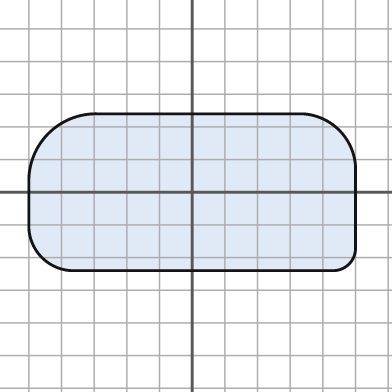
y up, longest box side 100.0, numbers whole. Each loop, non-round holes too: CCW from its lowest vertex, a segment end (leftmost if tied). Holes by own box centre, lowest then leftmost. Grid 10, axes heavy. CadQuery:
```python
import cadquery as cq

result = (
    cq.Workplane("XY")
    .moveTo(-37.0, -24.0)
    .lineTo(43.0, -24.0)
    .threePointArc((48.0, -22.0), (50.0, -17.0))
    .lineTo(50.0, 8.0)
    .threePointArc((45.0, 19.0), (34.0, 24.0))
    .lineTo(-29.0, 24.0)
    .threePointArc((-44.0, 18.0), (-50.0, 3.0))
    .lineTo(-50.0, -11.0)
    .threePointArc((-46.0, -20.0), (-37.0, -24.0))
    .close()
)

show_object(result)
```